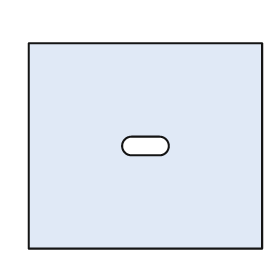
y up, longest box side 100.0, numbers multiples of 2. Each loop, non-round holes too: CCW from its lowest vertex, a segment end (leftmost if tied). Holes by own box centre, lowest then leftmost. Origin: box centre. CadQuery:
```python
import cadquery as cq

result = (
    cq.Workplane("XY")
    .moveTo(-50.0, -44.0)
    .lineTo(50.0, -44.0)
    .lineTo(50.0, 44.0)
    .lineTo(-50.0, 44.0)
    .close()
    .moveTo(-6.0, -4.0)
    .lineTo(6.0, -4.0)
    .threePointArc((10.0, 0.0), (6.0, 4.0))
    .lineTo(-6.0, 4.0)
    .threePointArc((-10.0, 0.0), (-6.0, -4.0))
    .close()
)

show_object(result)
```